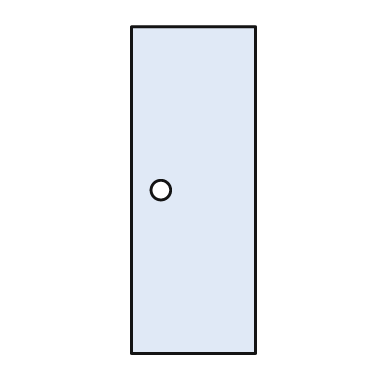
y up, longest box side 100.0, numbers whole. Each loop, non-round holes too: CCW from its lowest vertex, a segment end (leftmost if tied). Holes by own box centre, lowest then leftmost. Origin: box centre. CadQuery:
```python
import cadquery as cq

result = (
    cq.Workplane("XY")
    .moveTo(-19.0, -50.0)
    .lineTo(19.0, -50.0)
    .lineTo(19.0, 50.0)
    .lineTo(-19.0, 50.0)
    .close()
    .moveTo(-10.0, 0.0)
    .circle(3.0)
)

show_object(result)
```